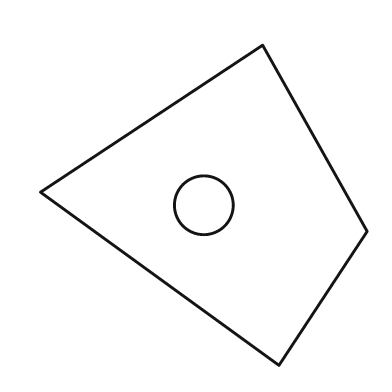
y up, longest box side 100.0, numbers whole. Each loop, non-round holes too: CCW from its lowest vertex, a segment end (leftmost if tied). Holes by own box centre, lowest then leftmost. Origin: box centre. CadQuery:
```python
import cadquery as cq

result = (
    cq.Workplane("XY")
    .moveTo(23.0, -49.0)
    .lineTo(50.0, -8.0)
    .lineTo(18.0, 49.0)
    .lineTo(-50.0, 4.0)
    .close()
    .moveTo(0.0, 0.0)
    .circle(9.0)
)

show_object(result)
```